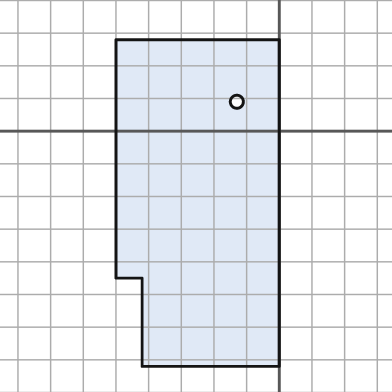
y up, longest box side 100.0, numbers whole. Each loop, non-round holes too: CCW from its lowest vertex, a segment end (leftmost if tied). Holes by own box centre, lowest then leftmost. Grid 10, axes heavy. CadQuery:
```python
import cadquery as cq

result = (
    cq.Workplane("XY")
    .moveTo(-42.0, -72.0)
    .lineTo(0.0, -72.0)
    .lineTo(0.0, 28.0)
    .lineTo(-50.0, 28.0)
    .lineTo(-50.0, -45.0)
    .lineTo(-42.0, -45.0)
    .close()
    .moveTo(-13.0, 9.0)
    .circle(2.0)
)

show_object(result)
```